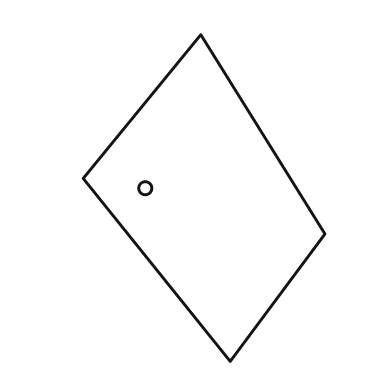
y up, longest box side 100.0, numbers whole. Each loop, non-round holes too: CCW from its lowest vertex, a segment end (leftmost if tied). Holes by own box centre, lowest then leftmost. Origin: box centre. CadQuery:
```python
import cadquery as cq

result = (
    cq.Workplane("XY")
    .moveTo(8.0, -50.0)
    .lineTo(37.0, -11.0)
    .lineTo(-1.0, 50.0)
    .lineTo(-37.0, 6.0)
    .close()
    .moveTo(-18.0, 3.0)
    .circle(2.0)
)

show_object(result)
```